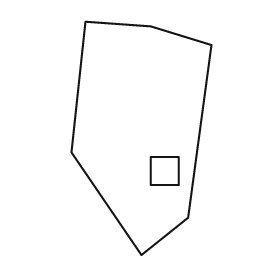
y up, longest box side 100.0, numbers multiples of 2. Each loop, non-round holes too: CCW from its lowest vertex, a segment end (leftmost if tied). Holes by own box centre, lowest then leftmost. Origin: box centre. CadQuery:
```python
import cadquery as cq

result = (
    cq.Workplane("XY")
    .moveTo(0.0, -50.0)
    .lineTo(20.0, -34.0)
    .lineTo(30.0, 40.0)
    .lineTo(4.0, 48.0)
    .lineTo(-24.0, 50.0)
    .lineTo(-30.0, -6.0)
    .close()
    .moveTo(4.0, -20.0)
    .lineTo(16.0, -20.0)
    .lineTo(16.0, -8.0)
    .lineTo(4.0, -8.0)
    .close()
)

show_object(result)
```